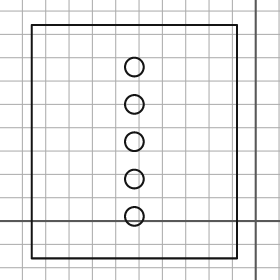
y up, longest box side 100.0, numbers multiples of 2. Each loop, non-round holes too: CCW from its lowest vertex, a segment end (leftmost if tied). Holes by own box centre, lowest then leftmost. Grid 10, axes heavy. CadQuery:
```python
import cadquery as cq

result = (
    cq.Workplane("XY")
    .moveTo(-96.0, -16.0)
    .lineTo(-8.0, -16.0)
    .lineTo(-8.0, 84.0)
    .lineTo(-96.0, 84.0)
    .close()
    .moveTo(-52.0, 2.0)
    .circle(4.0)
    .moveTo(-52.0, 18.0)
    .circle(4.0)
    .moveTo(-52.0, 34.0)
    .circle(4.0)
    .moveTo(-52.0, 50.0)
    .circle(4.0)
    .moveTo(-52.0, 66.0)
    .circle(4.0)
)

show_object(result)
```